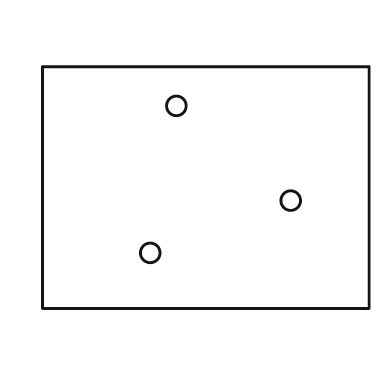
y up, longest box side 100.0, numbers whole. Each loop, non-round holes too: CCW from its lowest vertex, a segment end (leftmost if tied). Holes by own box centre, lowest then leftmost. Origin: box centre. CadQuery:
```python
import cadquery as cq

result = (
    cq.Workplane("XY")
    .moveTo(-50.0, -37.0)
    .lineTo(50.0, -37.0)
    .lineTo(50.0, 37.0)
    .lineTo(-50.0, 37.0)
    .close()
    .moveTo(-17.0, -20.0)
    .circle(3.0)
    .moveTo(26.0, -4.0)
    .circle(3.0)
    .moveTo(-9.0, 25.0)
    .circle(3.0)
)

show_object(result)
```